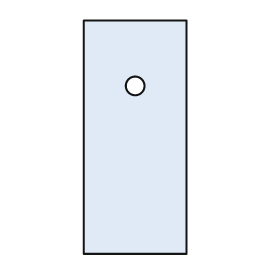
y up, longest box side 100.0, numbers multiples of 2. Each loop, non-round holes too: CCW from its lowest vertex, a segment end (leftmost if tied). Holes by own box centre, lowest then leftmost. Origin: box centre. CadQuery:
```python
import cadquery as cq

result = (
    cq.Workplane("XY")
    .moveTo(-22.0, -50.0)
    .lineTo(22.0, -50.0)
    .lineTo(22.0, 50.0)
    .lineTo(-22.0, 50.0)
    .close()
    .moveTo(0.0, 22.0)
    .circle(4.0)
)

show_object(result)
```